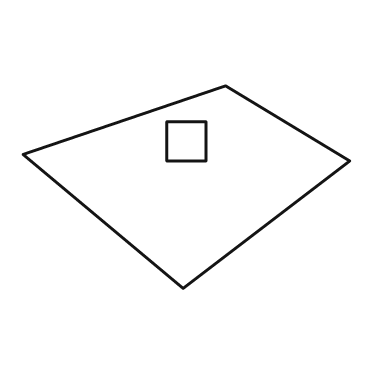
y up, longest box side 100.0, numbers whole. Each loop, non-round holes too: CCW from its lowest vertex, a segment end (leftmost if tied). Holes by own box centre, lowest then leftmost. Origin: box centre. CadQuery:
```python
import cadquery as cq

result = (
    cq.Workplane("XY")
    .moveTo(-1.0, -31.0)
    .lineTo(50.0, 8.0)
    .lineTo(12.0, 31.0)
    .lineTo(-50.0, 10.0)
    .close()
    .moveTo(-6.0, 8.0)
    .lineTo(6.0, 8.0)
    .lineTo(6.0, 20.0)
    .lineTo(-6.0, 20.0)
    .close()
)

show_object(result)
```